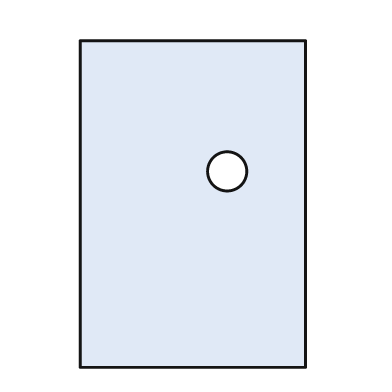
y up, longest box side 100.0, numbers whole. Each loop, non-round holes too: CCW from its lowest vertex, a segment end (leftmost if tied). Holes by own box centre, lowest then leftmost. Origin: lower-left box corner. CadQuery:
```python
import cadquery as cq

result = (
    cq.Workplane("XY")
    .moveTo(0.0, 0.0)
    .lineTo(69.0, 0.0)
    .lineTo(69.0, 100.0)
    .lineTo(0.0, 100.0)
    .close()
    .moveTo(45.0, 60.0)
    .circle(6.0)
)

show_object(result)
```